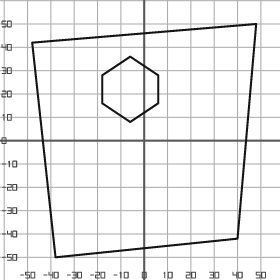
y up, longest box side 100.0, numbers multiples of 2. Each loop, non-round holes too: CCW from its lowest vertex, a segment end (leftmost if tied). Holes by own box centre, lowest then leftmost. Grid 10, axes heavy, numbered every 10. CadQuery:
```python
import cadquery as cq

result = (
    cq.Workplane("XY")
    .moveTo(-38.0, -50.0)
    .lineTo(40.0, -42.0)
    .lineTo(48.0, 50.0)
    .lineTo(-48.0, 42.0)
    .close()
    .moveTo(-6.0, 8.0)
    .lineTo(6.0, 16.0)
    .lineTo(6.0, 28.0)
    .lineTo(-6.0, 36.0)
    .lineTo(-18.0, 28.0)
    .lineTo(-18.0, 16.0)
    .close()
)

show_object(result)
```